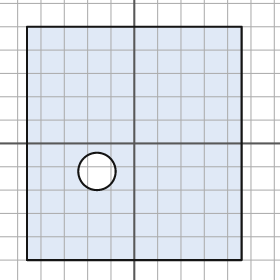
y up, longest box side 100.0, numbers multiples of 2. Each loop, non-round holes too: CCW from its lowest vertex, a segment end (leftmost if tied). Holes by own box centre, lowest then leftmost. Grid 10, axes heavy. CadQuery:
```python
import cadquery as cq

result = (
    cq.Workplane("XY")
    .moveTo(-46.0, -50.0)
    .lineTo(46.0, -50.0)
    .lineTo(46.0, 50.0)
    .lineTo(-46.0, 50.0)
    .close()
    .moveTo(-16.0, -12.0)
    .circle(8.0)
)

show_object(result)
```